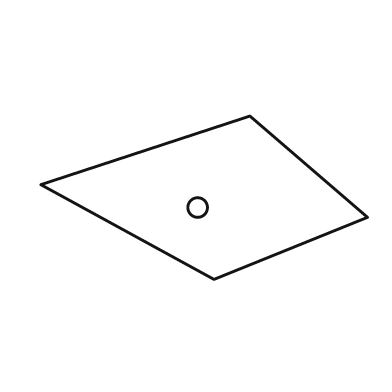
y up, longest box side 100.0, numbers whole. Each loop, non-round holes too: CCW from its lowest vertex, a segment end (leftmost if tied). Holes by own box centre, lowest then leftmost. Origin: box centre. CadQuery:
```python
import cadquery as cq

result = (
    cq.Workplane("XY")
    .moveTo(3.0, -25.0)
    .lineTo(50.0, -6.0)
    .lineTo(14.0, 25.0)
    .lineTo(-50.0, 4.0)
    .close()
    .moveTo(-2.0, -3.0)
    .circle(3.0)
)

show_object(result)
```